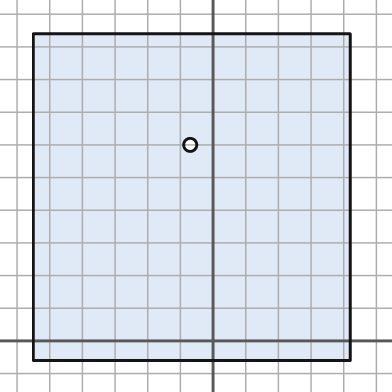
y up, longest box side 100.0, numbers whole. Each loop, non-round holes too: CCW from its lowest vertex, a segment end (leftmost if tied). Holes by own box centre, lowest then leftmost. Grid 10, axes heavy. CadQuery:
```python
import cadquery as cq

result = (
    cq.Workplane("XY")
    .moveTo(-55.0, -6.0)
    .lineTo(42.0, -6.0)
    .lineTo(42.0, 94.0)
    .lineTo(-55.0, 94.0)
    .close()
    .moveTo(-7.0, 60.0)
    .circle(2.0)
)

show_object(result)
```